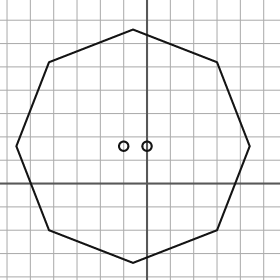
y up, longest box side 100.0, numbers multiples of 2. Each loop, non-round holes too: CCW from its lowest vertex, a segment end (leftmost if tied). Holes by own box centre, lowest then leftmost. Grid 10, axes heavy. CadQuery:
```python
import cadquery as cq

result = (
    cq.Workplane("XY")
    .moveTo(-6.0, -34.0)
    .lineTo(30.0, -20.0)
    .lineTo(44.0, 16.0)
    .lineTo(30.0, 52.0)
    .lineTo(-6.0, 66.0)
    .lineTo(-42.0, 52.0)
    .lineTo(-56.0, 16.0)
    .lineTo(-42.0, -20.0)
    .close()
    .moveTo(-10.0, 16.0)
    .circle(2.0)
    .moveTo(0.0, 16.0)
    .circle(2.0)
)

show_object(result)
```